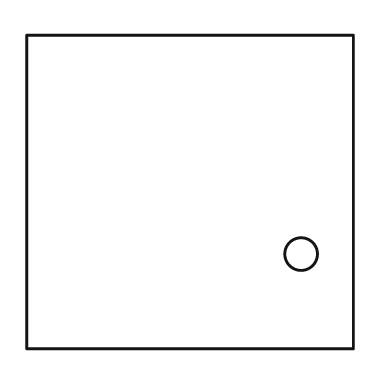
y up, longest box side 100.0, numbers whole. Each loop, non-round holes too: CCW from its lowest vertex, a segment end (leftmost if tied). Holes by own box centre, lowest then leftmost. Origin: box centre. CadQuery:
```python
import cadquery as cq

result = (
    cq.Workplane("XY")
    .moveTo(-50.0, -48.0)
    .lineTo(50.0, -48.0)
    .lineTo(50.0, 48.0)
    .lineTo(-50.0, 48.0)
    .close()
    .moveTo(34.0, -19.0)
    .circle(5.0)
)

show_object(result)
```